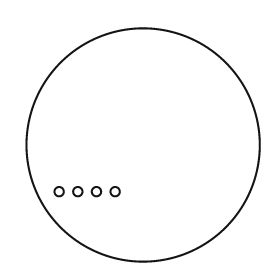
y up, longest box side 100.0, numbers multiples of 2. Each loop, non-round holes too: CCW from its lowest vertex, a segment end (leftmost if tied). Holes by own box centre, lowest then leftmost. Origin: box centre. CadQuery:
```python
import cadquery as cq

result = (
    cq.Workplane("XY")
    .moveTo(0.0, 0.0)
    .circle(50.0)
    .moveTo(-36.0, -20.0)
    .circle(2.0)
    .moveTo(-28.0, -20.0)
    .circle(2.0)
    .moveTo(-20.0, -20.0)
    .circle(2.0)
    .moveTo(-12.0, -20.0)
    .circle(2.0)
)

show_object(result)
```